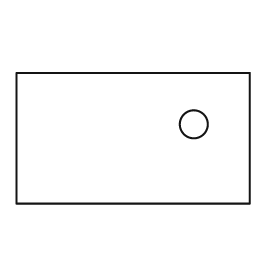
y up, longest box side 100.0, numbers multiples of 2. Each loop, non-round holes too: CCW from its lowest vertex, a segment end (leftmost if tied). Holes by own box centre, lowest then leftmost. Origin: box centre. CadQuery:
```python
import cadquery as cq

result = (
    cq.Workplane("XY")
    .moveTo(-50.0, -28.0)
    .lineTo(50.0, -28.0)
    .lineTo(50.0, 28.0)
    .lineTo(-50.0, 28.0)
    .close()
    .moveTo(26.0, 6.0)
    .circle(6.0)
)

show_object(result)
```